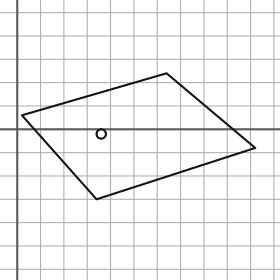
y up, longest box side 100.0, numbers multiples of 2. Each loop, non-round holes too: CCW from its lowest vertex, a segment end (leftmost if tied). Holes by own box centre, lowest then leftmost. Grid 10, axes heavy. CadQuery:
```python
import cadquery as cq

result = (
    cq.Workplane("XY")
    .moveTo(34.0, -30.0)
    .lineTo(102.0, -8.0)
    .lineTo(64.0, 24.0)
    .lineTo(2.0, 6.0)
    .close()
    .moveTo(36.0, -2.0)
    .circle(2.0)
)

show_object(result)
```